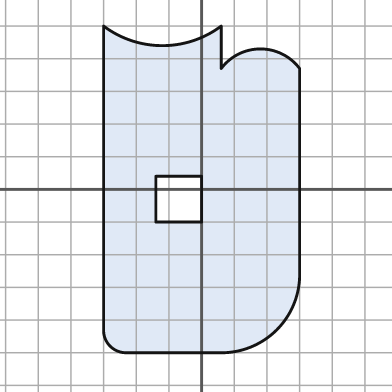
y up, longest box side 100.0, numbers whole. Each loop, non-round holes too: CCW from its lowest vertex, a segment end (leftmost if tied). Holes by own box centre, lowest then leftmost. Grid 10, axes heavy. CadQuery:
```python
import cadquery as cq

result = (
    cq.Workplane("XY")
    .moveTo(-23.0, -50.0)
    .lineTo(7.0, -50.0)
    .threePointArc((23.0, -43.0), (30.0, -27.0))
    .lineTo(30.0, 37.0)
    .threePointArc((18.0, 43.0), (6.0, 37.0))
    .lineTo(6.0, 50.0)
    .threePointArc((-12.0, 44.0), (-30.0, 50.0))
    .lineTo(-30.0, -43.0)
    .threePointArc((-28.0, -48.0), (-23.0, -50.0))
    .close()
    .moveTo(-14.0, -10.0)
    .lineTo(0.0, -10.0)
    .lineTo(0.0, 4.0)
    .lineTo(-14.0, 4.0)
    .close()
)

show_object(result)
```